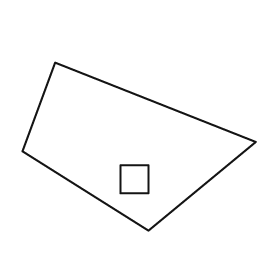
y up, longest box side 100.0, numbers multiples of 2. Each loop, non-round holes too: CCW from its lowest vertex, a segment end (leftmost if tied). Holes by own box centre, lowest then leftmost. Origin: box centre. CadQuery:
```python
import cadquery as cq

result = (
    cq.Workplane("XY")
    .moveTo(4.0, -36.0)
    .lineTo(50.0, 2.0)
    .lineTo(-36.0, 36.0)
    .lineTo(-50.0, -2.0)
    .close()
    .moveTo(-8.0, -20.0)
    .lineTo(4.0, -20.0)
    .lineTo(4.0, -8.0)
    .lineTo(-8.0, -8.0)
    .close()
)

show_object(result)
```